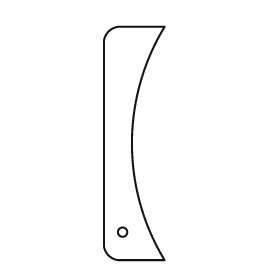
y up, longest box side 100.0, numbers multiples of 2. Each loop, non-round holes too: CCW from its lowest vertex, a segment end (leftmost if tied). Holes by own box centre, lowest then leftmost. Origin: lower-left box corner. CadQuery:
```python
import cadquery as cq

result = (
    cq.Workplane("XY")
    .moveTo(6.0, 0.0)
    .lineTo(26.0, 0.0)
    .threePointArc((12.0, 50.0), (26.0, 100.0))
    .lineTo(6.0, 100.0)
    .threePointArc((2.0, 98.0), (0.0, 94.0))
    .lineTo(0.0, 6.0)
    .threePointArc((2.0, 2.0), (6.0, 0.0))
    .close()
    .moveTo(8.0, 12.0)
    .circle(2.0)
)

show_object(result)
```